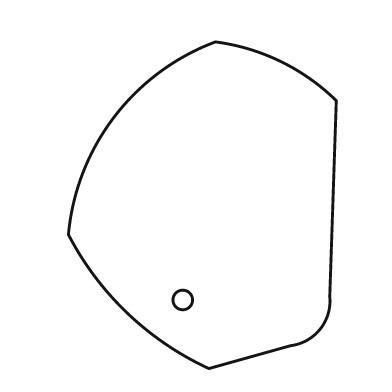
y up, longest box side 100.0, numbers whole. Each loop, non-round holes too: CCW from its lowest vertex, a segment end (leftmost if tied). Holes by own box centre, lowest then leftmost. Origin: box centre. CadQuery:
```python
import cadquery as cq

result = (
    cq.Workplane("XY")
    .moveTo(2.0, -50.0)
    .lineTo(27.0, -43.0)
    .threePointArc((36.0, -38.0), (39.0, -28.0))
    .lineTo(41.0, 32.0)
    .threePointArc((24.0, 44.0), (4.0, 50.0))
    .threePointArc((-27.0, 27.0), (-41.0, -9.0))
    .threePointArc((-23.0, -33.0), (2.0, -50.0))
    .close()
    .moveTo(-6.0, -29.0)
    .circle(3.0)
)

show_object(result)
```